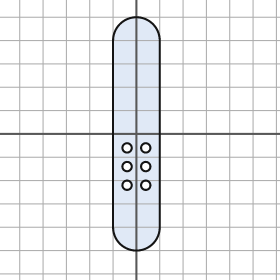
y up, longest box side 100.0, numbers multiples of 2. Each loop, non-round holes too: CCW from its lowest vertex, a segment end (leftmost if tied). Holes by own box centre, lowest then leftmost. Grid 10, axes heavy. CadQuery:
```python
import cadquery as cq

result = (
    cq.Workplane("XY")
    .moveTo(-10.0, -40.0)
    .threePointArc((0.0, -50.0), (10.0, -40.0))
    .lineTo(10.0, 40.0)
    .threePointArc((0.0, 50.0), (-10.0, 40.0))
    .close()
    .moveTo(-4.0, -22.0)
    .circle(2.0)
    .moveTo(4.0, -22.0)
    .circle(2.0)
    .moveTo(-4.0, -14.0)
    .circle(2.0)
    .moveTo(4.0, -14.0)
    .circle(2.0)
    .moveTo(-4.0, -6.0)
    .circle(2.0)
    .moveTo(4.0, -6.0)
    .circle(2.0)
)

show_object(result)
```